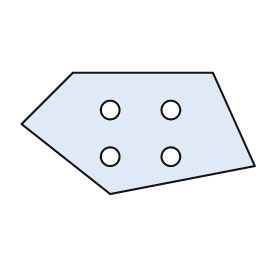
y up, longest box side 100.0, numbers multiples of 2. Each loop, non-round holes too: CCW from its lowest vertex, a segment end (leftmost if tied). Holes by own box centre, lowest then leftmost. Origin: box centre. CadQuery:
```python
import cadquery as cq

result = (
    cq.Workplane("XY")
    .moveTo(-12.0, -26.0)
    .lineTo(50.0, -14.0)
    .lineTo(32.0, 26.0)
    .lineTo(-28.0, 26.0)
    .lineTo(-50.0, 4.0)
    .close()
    .moveTo(-12.0, -10.0)
    .circle(4.0)
    .moveTo(14.0, -10.0)
    .circle(4.0)
    .moveTo(-12.0, 10.0)
    .circle(4.0)
    .moveTo(14.0, 10.0)
    .circle(4.0)
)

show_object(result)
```